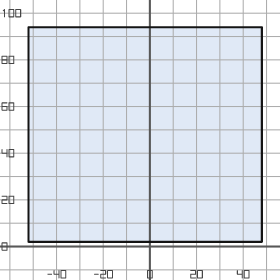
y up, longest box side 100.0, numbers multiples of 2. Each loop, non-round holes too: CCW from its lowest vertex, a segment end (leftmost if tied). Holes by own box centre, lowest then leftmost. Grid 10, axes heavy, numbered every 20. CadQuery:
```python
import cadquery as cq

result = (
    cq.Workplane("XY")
    .moveTo(-52.0, 2.0)
    .lineTo(48.0, 2.0)
    .lineTo(48.0, 94.0)
    .lineTo(-52.0, 94.0)
    .close()
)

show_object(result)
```